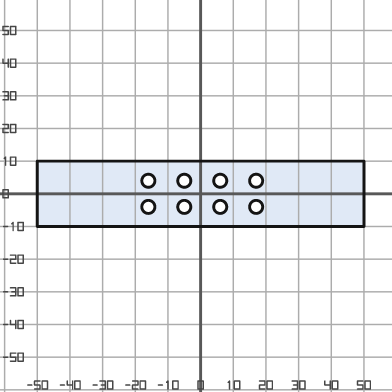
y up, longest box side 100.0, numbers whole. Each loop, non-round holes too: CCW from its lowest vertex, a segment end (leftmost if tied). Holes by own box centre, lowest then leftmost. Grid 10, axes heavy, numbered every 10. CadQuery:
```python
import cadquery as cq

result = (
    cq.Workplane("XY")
    .moveTo(-50.0, -10.0)
    .lineTo(50.0, -10.0)
    .lineTo(50.0, 10.0)
    .lineTo(-50.0, 10.0)
    .close()
    .moveTo(-16.0, -4.0)
    .circle(2.0)
    .moveTo(-5.0, -4.0)
    .circle(2.0)
    .moveTo(6.0, -4.0)
    .circle(2.0)
    .moveTo(17.0, -4.0)
    .circle(2.0)
    .moveTo(-16.0, 4.0)
    .circle(2.0)
    .moveTo(-5.0, 4.0)
    .circle(2.0)
    .moveTo(6.0, 4.0)
    .circle(2.0)
    .moveTo(17.0, 4.0)
    .circle(2.0)
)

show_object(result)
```